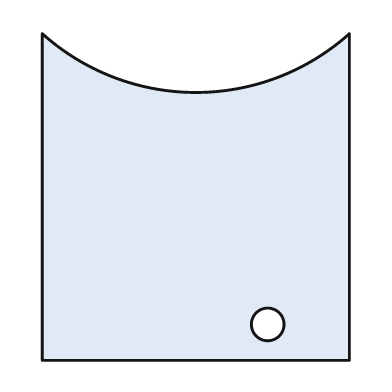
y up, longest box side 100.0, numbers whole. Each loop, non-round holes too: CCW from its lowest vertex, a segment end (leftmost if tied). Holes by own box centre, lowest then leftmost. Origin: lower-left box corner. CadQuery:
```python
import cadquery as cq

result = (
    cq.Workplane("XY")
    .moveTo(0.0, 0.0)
    .lineTo(94.0, 0.0)
    .lineTo(94.0, 100.0)
    .threePointArc((47.0, 82.0), (0.0, 100.0))
    .close()
    .moveTo(69.0, 11.0)
    .circle(5.0)
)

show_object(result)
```